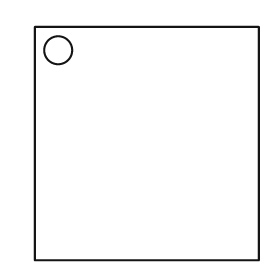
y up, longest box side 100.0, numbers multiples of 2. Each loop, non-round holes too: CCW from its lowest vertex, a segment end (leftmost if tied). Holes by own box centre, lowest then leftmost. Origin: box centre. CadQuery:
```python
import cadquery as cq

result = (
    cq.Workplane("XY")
    .moveTo(-48.0, -50.0)
    .lineTo(48.0, -50.0)
    .lineTo(48.0, 50.0)
    .lineTo(-48.0, 50.0)
    .close()
    .moveTo(-38.0, 40.0)
    .circle(6.0)
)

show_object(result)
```